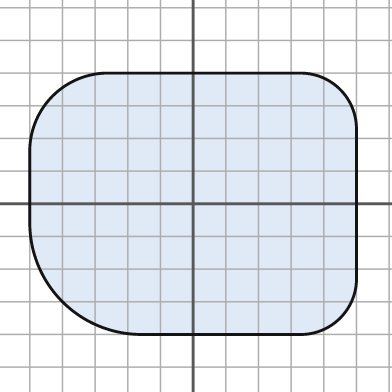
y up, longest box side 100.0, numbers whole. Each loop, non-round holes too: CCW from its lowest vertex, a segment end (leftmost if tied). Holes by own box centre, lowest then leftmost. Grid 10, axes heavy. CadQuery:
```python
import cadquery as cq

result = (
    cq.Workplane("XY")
    .moveTo(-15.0, -40.0)
    .lineTo(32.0, -40.0)
    .threePointArc((45.0, -35.0), (50.0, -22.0))
    .lineTo(50.0, 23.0)
    .threePointArc((45.0, 35.0), (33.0, 40.0))
    .lineTo(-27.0, 40.0)
    .threePointArc((-43.0, 33.0), (-50.0, 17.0))
    .lineTo(-50.0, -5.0)
    .threePointArc((-40.0, -30.0), (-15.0, -40.0))
    .close()
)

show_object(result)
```